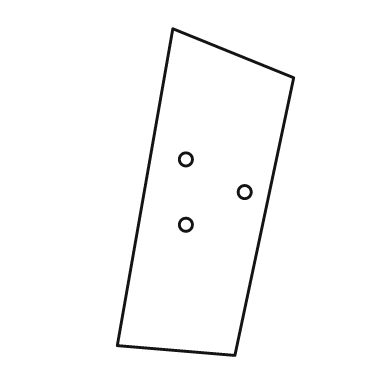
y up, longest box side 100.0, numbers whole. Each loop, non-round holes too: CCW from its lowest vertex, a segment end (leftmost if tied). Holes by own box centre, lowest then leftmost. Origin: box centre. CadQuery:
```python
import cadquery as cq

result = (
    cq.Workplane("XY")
    .moveTo(9.0, -50.0)
    .lineTo(27.0, 35.0)
    .lineTo(-10.0, 50.0)
    .lineTo(-27.0, -47.0)
    .close()
    .moveTo(-6.0, -10.0)
    .circle(2.0)
    .moveTo(12.0, 0.0)
    .circle(2.0)
    .moveTo(-6.0, 10.0)
    .circle(2.0)
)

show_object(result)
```